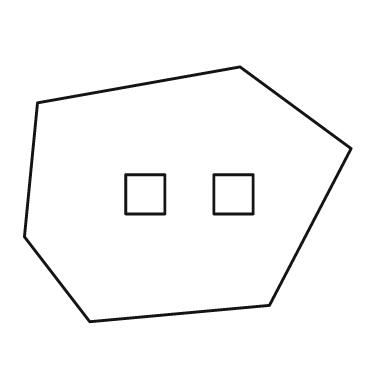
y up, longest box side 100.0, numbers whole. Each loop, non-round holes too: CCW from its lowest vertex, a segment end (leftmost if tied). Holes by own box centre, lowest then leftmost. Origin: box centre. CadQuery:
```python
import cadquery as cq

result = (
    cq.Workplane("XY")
    .moveTo(-30.0, -39.0)
    .lineTo(25.0, -34.0)
    .lineTo(50.0, 14.0)
    .lineTo(16.0, 39.0)
    .lineTo(-46.0, 28.0)
    .lineTo(-50.0, -13.0)
    .close()
    .moveTo(-19.0, -6.0)
    .lineTo(-7.0, -6.0)
    .lineTo(-7.0, 6.0)
    .lineTo(-19.0, 6.0)
    .close()
    .moveTo(8.0, -6.0)
    .lineTo(20.0, -6.0)
    .lineTo(20.0, 6.0)
    .lineTo(8.0, 6.0)
    .close()
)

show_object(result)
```